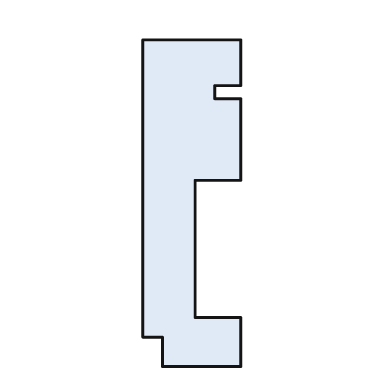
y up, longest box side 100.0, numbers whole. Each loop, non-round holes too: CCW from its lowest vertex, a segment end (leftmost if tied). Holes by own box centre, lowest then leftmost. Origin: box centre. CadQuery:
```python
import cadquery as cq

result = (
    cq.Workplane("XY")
    .moveTo(-9.0, -50.0)
    .lineTo(15.0, -50.0)
    .lineTo(15.0, -35.0)
    .lineTo(1.0, -35.0)
    .lineTo(1.0, 7.0)
    .lineTo(15.0, 7.0)
    .lineTo(15.0, 32.0)
    .lineTo(7.0, 32.0)
    .lineTo(7.0, 36.0)
    .lineTo(15.0, 36.0)
    .lineTo(15.0, 50.0)
    .lineTo(-15.0, 50.0)
    .lineTo(-15.0, -41.0)
    .lineTo(-9.0, -41.0)
    .close()
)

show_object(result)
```